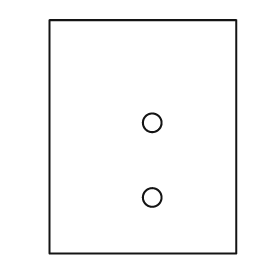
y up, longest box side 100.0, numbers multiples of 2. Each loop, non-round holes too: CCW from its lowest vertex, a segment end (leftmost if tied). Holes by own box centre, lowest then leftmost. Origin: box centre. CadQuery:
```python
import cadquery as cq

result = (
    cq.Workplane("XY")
    .moveTo(-40.0, -50.0)
    .lineTo(40.0, -50.0)
    .lineTo(40.0, 50.0)
    .lineTo(-40.0, 50.0)
    .close()
    .moveTo(4.0, -26.0)
    .circle(4.0)
    .moveTo(4.0, 6.0)
    .circle(4.0)
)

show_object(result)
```